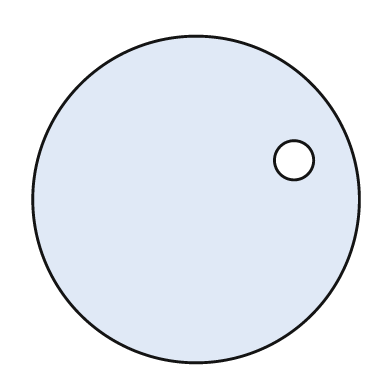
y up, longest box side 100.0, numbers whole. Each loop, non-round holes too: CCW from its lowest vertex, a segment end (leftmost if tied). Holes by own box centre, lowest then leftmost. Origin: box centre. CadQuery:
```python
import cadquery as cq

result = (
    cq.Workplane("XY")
    .moveTo(0.0, 0.0)
    .circle(50.0)
    .moveTo(30.0, 12.0)
    .circle(6.0)
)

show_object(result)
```